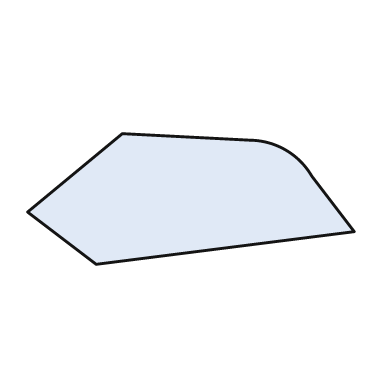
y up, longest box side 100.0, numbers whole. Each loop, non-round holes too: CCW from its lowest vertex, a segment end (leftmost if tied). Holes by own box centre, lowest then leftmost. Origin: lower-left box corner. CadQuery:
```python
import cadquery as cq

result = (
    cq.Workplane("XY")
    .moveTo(21.0, 0.0)
    .lineTo(100.0, 10.0)
    .lineTo(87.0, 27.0)
    .threePointArc((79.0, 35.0), (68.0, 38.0))
    .lineTo(29.0, 40.0)
    .lineTo(0.0, 16.0)
    .close()
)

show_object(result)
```